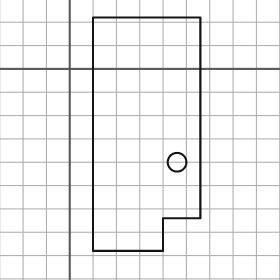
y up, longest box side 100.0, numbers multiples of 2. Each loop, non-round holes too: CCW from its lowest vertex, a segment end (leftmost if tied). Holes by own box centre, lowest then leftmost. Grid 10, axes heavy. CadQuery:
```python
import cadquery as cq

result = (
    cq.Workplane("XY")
    .moveTo(10.0, -78.0)
    .lineTo(40.0, -78.0)
    .lineTo(40.0, -64.0)
    .lineTo(56.0, -64.0)
    .lineTo(56.0, 22.0)
    .lineTo(10.0, 22.0)
    .close()
    .moveTo(46.0, -40.0)
    .circle(4.0)
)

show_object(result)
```